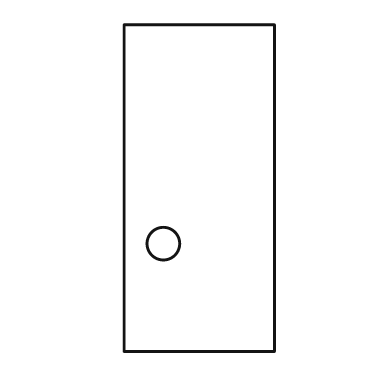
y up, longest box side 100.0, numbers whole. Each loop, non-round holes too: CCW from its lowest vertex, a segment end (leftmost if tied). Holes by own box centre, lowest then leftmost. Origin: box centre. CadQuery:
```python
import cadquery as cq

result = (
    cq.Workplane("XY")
    .moveTo(-23.0, -50.0)
    .lineTo(23.0, -50.0)
    .lineTo(23.0, 50.0)
    .lineTo(-23.0, 50.0)
    .close()
    .moveTo(-11.0, -17.0)
    .circle(5.0)
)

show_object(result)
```